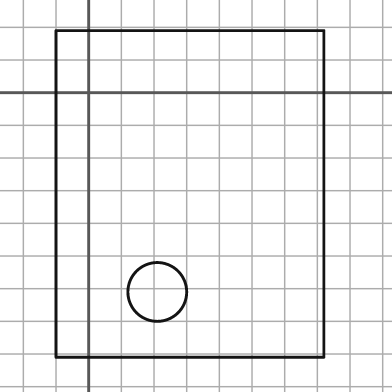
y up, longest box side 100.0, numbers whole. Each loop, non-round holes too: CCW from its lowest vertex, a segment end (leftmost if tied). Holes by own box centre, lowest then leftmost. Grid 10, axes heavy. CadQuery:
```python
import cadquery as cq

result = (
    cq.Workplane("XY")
    .moveTo(-10.0, -81.0)
    .lineTo(72.0, -81.0)
    .lineTo(72.0, 19.0)
    .lineTo(-10.0, 19.0)
    .close()
    .moveTo(21.0, -61.0)
    .circle(9.0)
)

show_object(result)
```